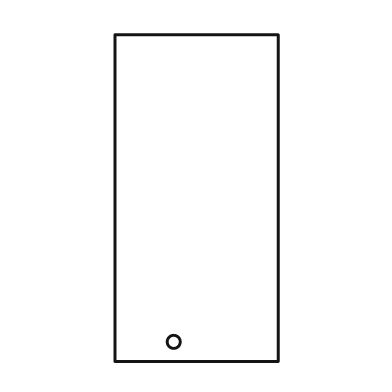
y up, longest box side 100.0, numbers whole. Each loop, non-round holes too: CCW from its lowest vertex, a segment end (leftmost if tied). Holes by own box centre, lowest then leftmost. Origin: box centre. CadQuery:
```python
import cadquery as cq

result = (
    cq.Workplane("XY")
    .moveTo(-25.0, -50.0)
    .lineTo(25.0, -50.0)
    .lineTo(25.0, 50.0)
    .lineTo(-25.0, 50.0)
    .close()
    .moveTo(-7.0, -44.0)
    .circle(2.0)
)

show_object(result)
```